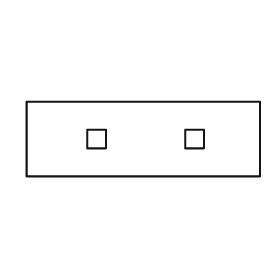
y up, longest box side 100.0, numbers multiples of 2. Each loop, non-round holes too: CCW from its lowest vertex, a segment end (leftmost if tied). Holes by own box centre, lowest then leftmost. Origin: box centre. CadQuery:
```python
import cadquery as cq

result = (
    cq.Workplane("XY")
    .moveTo(-50.0, -16.0)
    .lineTo(50.0, -16.0)
    .lineTo(50.0, 16.0)
    .lineTo(-50.0, 16.0)
    .close()
    .moveTo(-24.0, -4.0)
    .lineTo(-16.0, -4.0)
    .lineTo(-16.0, 4.0)
    .lineTo(-24.0, 4.0)
    .close()
    .moveTo(18.0, -4.0)
    .lineTo(26.0, -4.0)
    .lineTo(26.0, 4.0)
    .lineTo(18.0, 4.0)
    .close()
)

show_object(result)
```